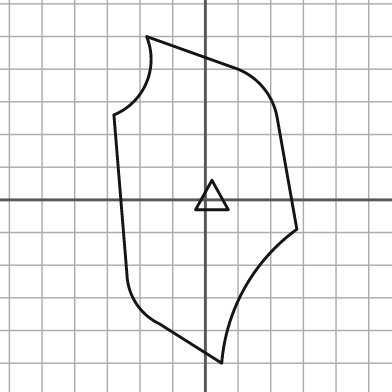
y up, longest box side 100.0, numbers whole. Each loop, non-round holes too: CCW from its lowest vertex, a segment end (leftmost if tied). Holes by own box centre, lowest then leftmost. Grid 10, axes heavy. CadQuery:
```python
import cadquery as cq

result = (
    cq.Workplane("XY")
    .moveTo(5.0, -50.0)
    .threePointArc((12.0, -27.0), (28.0, -9.0))
    .lineTo(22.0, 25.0)
    .threePointArc((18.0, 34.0), (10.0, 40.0))
    .lineTo(-18.0, 50.0)
    .threePointArc((-18.0, 36.0), (-28.0, 26.0))
    .lineTo(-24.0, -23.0)
    .threePointArc((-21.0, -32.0), (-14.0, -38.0))
    .close()
    .moveTo(-3.0, -3.0)
    .lineTo(7.0, -3.0)
    .lineTo(2.0, 6.0)
    .close()
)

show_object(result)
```